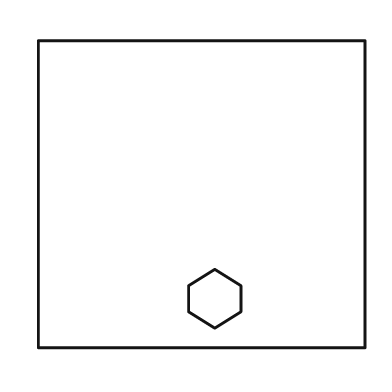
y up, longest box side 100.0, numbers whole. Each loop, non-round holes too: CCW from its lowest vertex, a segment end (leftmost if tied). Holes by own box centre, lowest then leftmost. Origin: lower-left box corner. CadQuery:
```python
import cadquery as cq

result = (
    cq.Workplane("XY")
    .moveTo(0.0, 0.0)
    .lineTo(100.0, 0.0)
    .lineTo(100.0, 94.0)
    .lineTo(0.0, 94.0)
    .close()
    .moveTo(54.0, 6.0)
    .lineTo(62.0, 11.0)
    .lineTo(62.0, 19.0)
    .lineTo(54.0, 24.0)
    .lineTo(46.0, 19.0)
    .lineTo(46.0, 11.0)
    .close()
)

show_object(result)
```